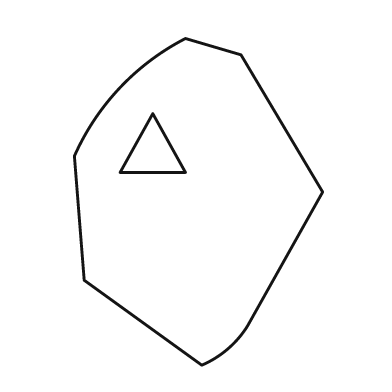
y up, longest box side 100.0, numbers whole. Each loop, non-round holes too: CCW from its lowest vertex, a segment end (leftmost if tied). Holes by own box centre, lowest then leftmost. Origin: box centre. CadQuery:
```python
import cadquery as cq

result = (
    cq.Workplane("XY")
    .moveTo(1.0, -50.0)
    .threePointArc((9.0, -45.0), (15.0, -38.0))
    .lineTo(38.0, 3.0)
    .lineTo(13.0, 45.0)
    .lineTo(-4.0, 50.0)
    .threePointArc((-24.0, 35.0), (-38.0, 14.0))
    .lineTo(-35.0, -24.0)
    .close()
    .moveTo(-24.0, 9.0)
    .lineTo(-4.0, 9.0)
    .lineTo(-14.0, 27.0)
    .close()
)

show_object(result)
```